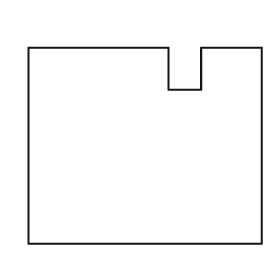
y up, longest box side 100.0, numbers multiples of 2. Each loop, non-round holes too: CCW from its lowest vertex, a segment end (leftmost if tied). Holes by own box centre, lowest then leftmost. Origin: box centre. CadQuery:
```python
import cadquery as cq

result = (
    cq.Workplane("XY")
    .moveTo(-50.0, -42.0)
    .lineTo(50.0, -42.0)
    .lineTo(50.0, 42.0)
    .lineTo(24.0, 42.0)
    .lineTo(24.0, 24.0)
    .lineTo(10.0, 24.0)
    .lineTo(10.0, 42.0)
    .lineTo(-50.0, 42.0)
    .close()
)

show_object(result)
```